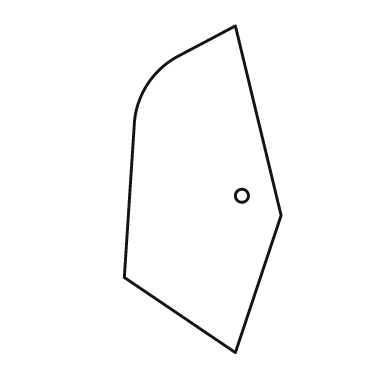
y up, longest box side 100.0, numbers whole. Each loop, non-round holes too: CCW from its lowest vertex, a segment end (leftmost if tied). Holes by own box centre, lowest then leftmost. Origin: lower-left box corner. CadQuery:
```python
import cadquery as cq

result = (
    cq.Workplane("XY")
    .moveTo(34.0, 0.0)
    .lineTo(48.0, 42.0)
    .lineTo(34.0, 100.0)
    .lineTo(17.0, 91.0)
    .threePointArc((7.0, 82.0), (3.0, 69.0))
    .lineTo(0.0, 23.0)
    .close()
    .moveTo(36.0, 48.0)
    .circle(2.0)
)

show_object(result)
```